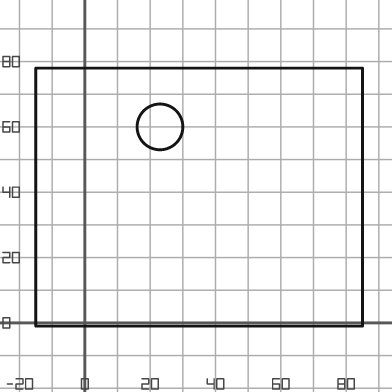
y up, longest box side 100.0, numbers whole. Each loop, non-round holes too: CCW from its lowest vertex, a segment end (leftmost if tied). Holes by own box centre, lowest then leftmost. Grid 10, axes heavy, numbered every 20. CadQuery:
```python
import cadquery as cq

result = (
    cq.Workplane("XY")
    .moveTo(-15.0, -1.0)
    .lineTo(85.0, -1.0)
    .lineTo(85.0, 78.0)
    .lineTo(-15.0, 78.0)
    .close()
    .moveTo(23.0, 60.0)
    .circle(7.0)
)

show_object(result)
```